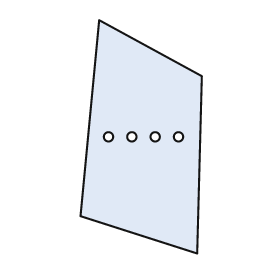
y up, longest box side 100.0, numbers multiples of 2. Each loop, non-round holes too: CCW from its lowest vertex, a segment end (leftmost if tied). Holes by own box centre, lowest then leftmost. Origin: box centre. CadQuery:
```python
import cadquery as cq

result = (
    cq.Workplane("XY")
    .moveTo(24.0, -50.0)
    .lineTo(26.0, 26.0)
    .lineTo(-18.0, 50.0)
    .lineTo(-26.0, -34.0)
    .close()
    .moveTo(-14.0, 0.0)
    .circle(2.0)
    .moveTo(-4.0, 0.0)
    .circle(2.0)
    .moveTo(6.0, 0.0)
    .circle(2.0)
    .moveTo(16.0, 0.0)
    .circle(2.0)
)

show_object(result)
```